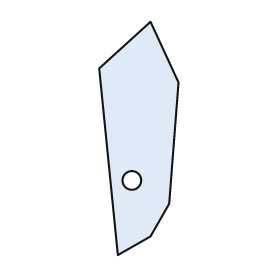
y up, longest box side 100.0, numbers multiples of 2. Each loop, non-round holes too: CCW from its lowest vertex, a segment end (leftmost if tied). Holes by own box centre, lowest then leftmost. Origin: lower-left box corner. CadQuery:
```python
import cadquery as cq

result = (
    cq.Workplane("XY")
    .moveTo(8.0, 0.0)
    .lineTo(22.0, 8.0)
    .lineTo(30.0, 22.0)
    .lineTo(34.0, 74.0)
    .lineTo(22.0, 100.0)
    .lineTo(0.0, 80.0)
    .close()
    .moveTo(14.0, 32.0)
    .circle(4.0)
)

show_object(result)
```